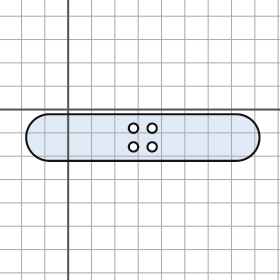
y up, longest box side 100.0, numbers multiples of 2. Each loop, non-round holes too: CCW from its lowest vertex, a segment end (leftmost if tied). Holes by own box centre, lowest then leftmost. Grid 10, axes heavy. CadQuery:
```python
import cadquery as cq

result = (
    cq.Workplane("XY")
    .moveTo(-8.0, -22.0)
    .lineTo(72.0, -22.0)
    .threePointArc((82.0, -12.0), (72.0, -2.0))
    .lineTo(-8.0, -2.0)
    .threePointArc((-18.0, -12.0), (-8.0, -22.0))
    .close()
    .moveTo(28.0, -16.0)
    .circle(2.0)
    .moveTo(36.0, -16.0)
    .circle(2.0)
    .moveTo(28.0, -8.0)
    .circle(2.0)
    .moveTo(36.0, -8.0)
    .circle(2.0)
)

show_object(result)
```